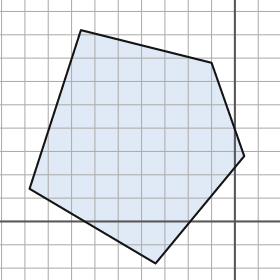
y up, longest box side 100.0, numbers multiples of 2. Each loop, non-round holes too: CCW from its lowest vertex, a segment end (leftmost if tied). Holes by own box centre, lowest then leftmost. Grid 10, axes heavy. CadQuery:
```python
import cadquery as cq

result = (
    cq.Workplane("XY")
    .moveTo(-34.0, -18.0)
    .lineTo(4.0, 28.0)
    .lineTo(-10.0, 68.0)
    .lineTo(-66.0, 82.0)
    .lineTo(-88.0, 14.0)
    .close()
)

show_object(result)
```